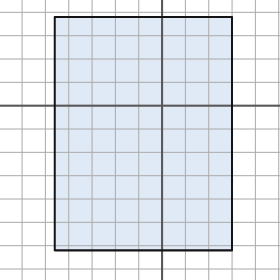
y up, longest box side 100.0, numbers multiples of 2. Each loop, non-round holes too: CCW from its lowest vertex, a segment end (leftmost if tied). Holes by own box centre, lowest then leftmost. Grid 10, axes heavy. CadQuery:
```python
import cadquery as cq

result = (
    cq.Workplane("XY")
    .moveTo(-46.0, -62.0)
    .lineTo(30.0, -62.0)
    .lineTo(30.0, 38.0)
    .lineTo(-46.0, 38.0)
    .close()
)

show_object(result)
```